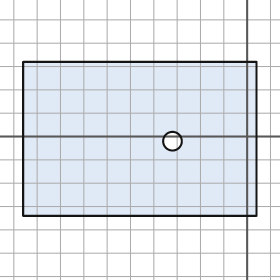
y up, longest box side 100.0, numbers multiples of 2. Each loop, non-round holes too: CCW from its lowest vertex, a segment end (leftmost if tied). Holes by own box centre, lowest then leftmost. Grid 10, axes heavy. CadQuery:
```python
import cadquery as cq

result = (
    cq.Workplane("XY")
    .moveTo(-96.0, -34.0)
    .lineTo(4.0, -34.0)
    .lineTo(4.0, 32.0)
    .lineTo(-96.0, 32.0)
    .close()
    .moveTo(-32.0, -2.0)
    .circle(4.0)
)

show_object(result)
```